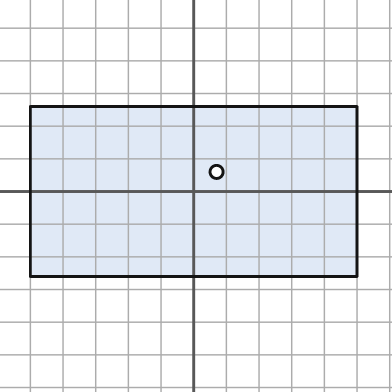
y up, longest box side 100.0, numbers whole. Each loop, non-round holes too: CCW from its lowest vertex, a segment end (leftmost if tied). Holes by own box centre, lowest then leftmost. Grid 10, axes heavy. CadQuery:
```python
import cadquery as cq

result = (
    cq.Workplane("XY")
    .moveTo(-50.0, -26.0)
    .lineTo(50.0, -26.0)
    .lineTo(50.0, 26.0)
    .lineTo(-50.0, 26.0)
    .close()
    .moveTo(7.0, 6.0)
    .circle(2.0)
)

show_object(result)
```